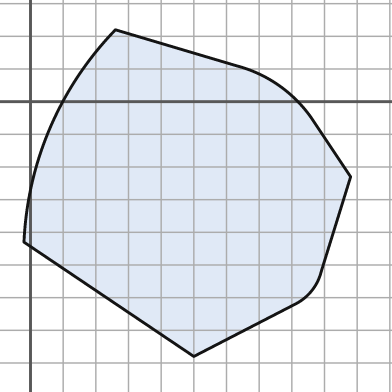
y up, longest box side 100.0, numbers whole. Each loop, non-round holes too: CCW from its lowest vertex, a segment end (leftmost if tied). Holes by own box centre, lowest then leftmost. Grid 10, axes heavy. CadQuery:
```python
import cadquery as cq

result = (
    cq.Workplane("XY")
    .moveTo(50.0, -78.0)
    .lineTo(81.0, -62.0)
    .threePointArc((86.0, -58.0), (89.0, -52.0))
    .lineTo(98.0, -23.0)
    .lineTo(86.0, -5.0)
    .threePointArc((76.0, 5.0), (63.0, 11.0))
    .lineTo(26.0, 22.0)
    .threePointArc((6.0, -8.0), (-2.0, -43.0))
    .close()
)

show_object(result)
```